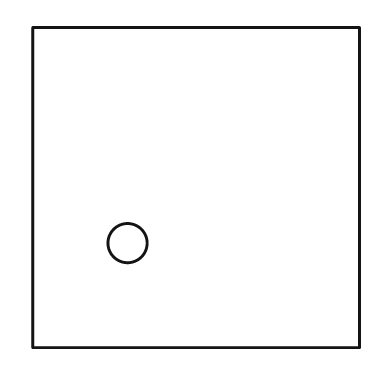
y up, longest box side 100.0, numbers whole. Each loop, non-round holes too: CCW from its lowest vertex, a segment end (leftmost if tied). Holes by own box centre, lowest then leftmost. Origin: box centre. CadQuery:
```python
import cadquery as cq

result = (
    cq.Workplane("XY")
    .moveTo(-50.0, -49.0)
    .lineTo(50.0, -49.0)
    .lineTo(50.0, 49.0)
    .lineTo(-50.0, 49.0)
    .close()
    .moveTo(-21.0, -17.0)
    .circle(6.0)
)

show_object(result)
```